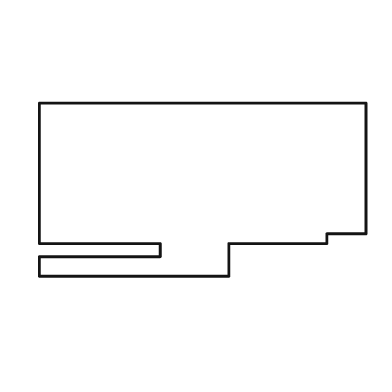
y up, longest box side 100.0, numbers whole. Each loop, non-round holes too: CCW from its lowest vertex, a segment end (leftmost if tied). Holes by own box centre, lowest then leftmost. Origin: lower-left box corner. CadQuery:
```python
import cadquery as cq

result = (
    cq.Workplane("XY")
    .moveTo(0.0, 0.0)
    .lineTo(58.0, 0.0)
    .lineTo(58.0, 10.0)
    .lineTo(88.0, 10.0)
    .lineTo(88.0, 13.0)
    .lineTo(100.0, 13.0)
    .lineTo(100.0, 53.0)
    .lineTo(0.0, 53.0)
    .lineTo(0.0, 10.0)
    .lineTo(37.0, 10.0)
    .lineTo(37.0, 6.0)
    .lineTo(0.0, 6.0)
    .close()
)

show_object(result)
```